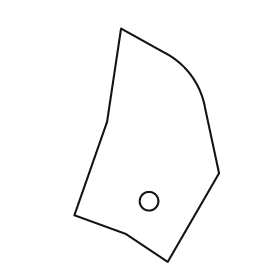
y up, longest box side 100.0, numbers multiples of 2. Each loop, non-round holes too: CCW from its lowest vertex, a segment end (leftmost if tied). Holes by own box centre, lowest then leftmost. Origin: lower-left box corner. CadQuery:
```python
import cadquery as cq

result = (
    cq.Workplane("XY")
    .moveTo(40.0, 0.0)
    .lineTo(62.0, 38.0)
    .lineTo(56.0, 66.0)
    .threePointArc((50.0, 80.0), (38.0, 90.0))
    .lineTo(20.0, 100.0)
    .lineTo(14.0, 60.0)
    .lineTo(0.0, 20.0)
    .lineTo(22.0, 12.0)
    .close()
    .moveTo(32.0, 26.0)
    .circle(4.0)
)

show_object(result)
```